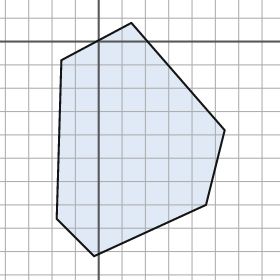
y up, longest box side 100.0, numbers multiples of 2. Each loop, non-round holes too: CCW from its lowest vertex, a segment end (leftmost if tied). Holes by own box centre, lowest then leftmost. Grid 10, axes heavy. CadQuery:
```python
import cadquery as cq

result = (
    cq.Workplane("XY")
    .moveTo(-2.0, -92.0)
    .lineTo(46.0, -70.0)
    .lineTo(54.0, -38.0)
    .lineTo(14.0, 8.0)
    .lineTo(-16.0, -8.0)
    .lineTo(-18.0, -76.0)
    .close()
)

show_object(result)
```